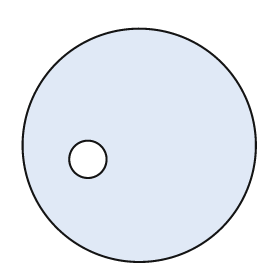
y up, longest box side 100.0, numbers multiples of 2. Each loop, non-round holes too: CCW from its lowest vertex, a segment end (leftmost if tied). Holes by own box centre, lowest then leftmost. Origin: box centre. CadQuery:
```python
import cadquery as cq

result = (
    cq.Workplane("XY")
    .moveTo(0.0, 0.0)
    .circle(50.0)
    .moveTo(-22.0, -6.0)
    .circle(8.0)
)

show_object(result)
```